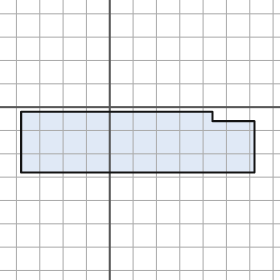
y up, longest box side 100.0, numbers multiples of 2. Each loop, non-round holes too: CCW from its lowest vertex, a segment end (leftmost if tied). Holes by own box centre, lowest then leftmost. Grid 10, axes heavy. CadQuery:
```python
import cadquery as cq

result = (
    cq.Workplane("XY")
    .moveTo(-38.0, -28.0)
    .lineTo(62.0, -28.0)
    .lineTo(62.0, -6.0)
    .lineTo(44.0, -6.0)
    .lineTo(44.0, -2.0)
    .lineTo(-38.0, -2.0)
    .close()
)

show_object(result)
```